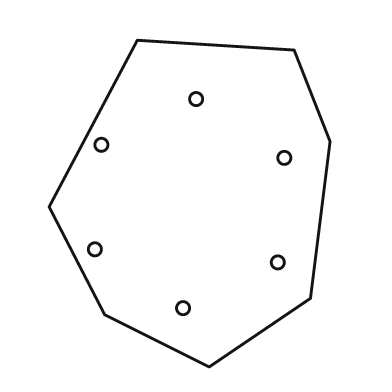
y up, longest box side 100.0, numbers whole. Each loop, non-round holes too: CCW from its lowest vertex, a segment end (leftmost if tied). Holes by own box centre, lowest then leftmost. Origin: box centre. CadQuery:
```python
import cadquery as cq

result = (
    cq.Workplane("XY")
    .moveTo(6.0, -50.0)
    .lineTo(37.0, -29.0)
    .lineTo(43.0, 19.0)
    .lineTo(32.0, 47.0)
    .lineTo(-16.0, 50.0)
    .lineTo(-43.0, -1.0)
    .lineTo(-26.0, -34.0)
    .close()
    .moveTo(-2.0, -32.0)
    .circle(2.0)
    .moveTo(27.0, -18.0)
    .circle(2.0)
    .moveTo(-29.0, -14.0)
    .circle(2.0)
    .moveTo(29.0, 14.0)
    .circle(2.0)
    .moveTo(-27.0, 18.0)
    .circle(2.0)
    .moveTo(2.0, 32.0)
    .circle(2.0)
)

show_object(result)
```